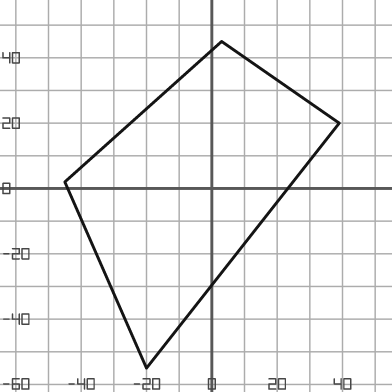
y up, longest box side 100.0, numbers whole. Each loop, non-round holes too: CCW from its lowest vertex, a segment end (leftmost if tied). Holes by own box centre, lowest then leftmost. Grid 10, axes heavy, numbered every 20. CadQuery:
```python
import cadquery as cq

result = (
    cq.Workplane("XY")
    .moveTo(-20.0, -55.0)
    .lineTo(39.0, 20.0)
    .lineTo(3.0, 45.0)
    .lineTo(-45.0, 2.0)
    .close()
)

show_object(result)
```